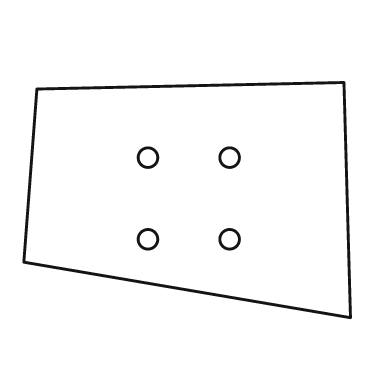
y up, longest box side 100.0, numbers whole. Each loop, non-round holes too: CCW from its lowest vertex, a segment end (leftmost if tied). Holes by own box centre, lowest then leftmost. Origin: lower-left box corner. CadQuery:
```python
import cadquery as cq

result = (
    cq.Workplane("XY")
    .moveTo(100.0, 0.0)
    .lineTo(98.0, 72.0)
    .lineTo(4.0, 70.0)
    .lineTo(0.0, 17.0)
    .close()
    .moveTo(38.0, 24.0)
    .circle(3.0)
    .moveTo(63.0, 24.0)
    .circle(3.0)
    .moveTo(38.0, 49.0)
    .circle(3.0)
    .moveTo(63.0, 49.0)
    .circle(3.0)
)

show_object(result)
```